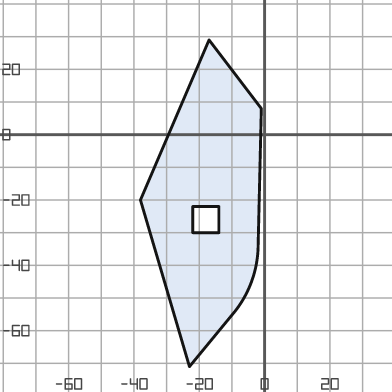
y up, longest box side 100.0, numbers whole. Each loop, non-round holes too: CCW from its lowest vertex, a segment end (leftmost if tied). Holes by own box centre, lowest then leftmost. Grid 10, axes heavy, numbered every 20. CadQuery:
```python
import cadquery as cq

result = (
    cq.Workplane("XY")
    .moveTo(-23.0, -71.0)
    .lineTo(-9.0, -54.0)
    .threePointArc((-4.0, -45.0), (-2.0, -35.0))
    .lineTo(-1.0, 8.0)
    .lineTo(-17.0, 29.0)
    .lineTo(-38.0, -20.0)
    .close()
    .moveTo(-22.0, -30.0)
    .lineTo(-14.0, -30.0)
    .lineTo(-14.0, -22.0)
    .lineTo(-22.0, -22.0)
    .close()
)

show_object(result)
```